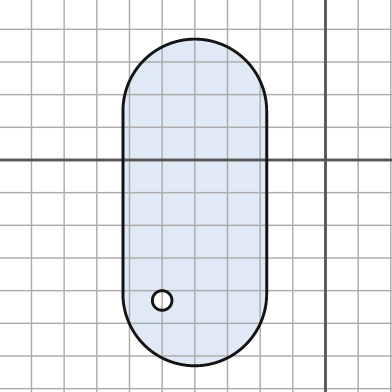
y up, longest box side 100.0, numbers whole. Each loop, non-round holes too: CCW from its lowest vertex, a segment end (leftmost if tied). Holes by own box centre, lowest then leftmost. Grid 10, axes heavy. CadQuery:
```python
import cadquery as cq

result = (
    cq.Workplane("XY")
    .moveTo(-62.0, -41.0)
    .threePointArc((-40.0, -63.0), (-18.0, -41.0))
    .lineTo(-18.0, 15.0)
    .threePointArc((-40.0, 37.0), (-62.0, 15.0))
    .close()
    .moveTo(-50.0, -43.0)
    .circle(3.0)
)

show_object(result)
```